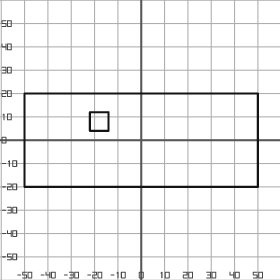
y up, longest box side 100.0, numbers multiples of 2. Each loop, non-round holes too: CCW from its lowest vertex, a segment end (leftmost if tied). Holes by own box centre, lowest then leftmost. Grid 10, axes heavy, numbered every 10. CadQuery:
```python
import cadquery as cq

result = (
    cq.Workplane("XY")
    .moveTo(-50.0, -20.0)
    .lineTo(50.0, -20.0)
    .lineTo(50.0, 20.0)
    .lineTo(-50.0, 20.0)
    .close()
    .moveTo(-22.0, 4.0)
    .lineTo(-14.0, 4.0)
    .lineTo(-14.0, 12.0)
    .lineTo(-22.0, 12.0)
    .close()
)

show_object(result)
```